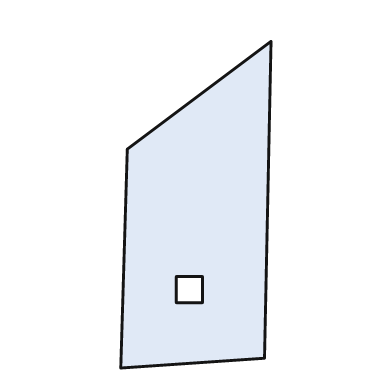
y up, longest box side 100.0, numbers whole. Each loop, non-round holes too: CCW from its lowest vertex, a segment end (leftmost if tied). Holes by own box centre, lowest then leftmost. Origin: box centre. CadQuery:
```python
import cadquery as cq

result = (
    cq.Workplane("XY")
    .moveTo(-23.0, -50.0)
    .lineTo(21.0, -47.0)
    .lineTo(23.0, 50.0)
    .lineTo(-21.0, 17.0)
    .close()
    .moveTo(-6.0, -30.0)
    .lineTo(2.0, -30.0)
    .lineTo(2.0, -22.0)
    .lineTo(-6.0, -22.0)
    .close()
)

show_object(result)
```